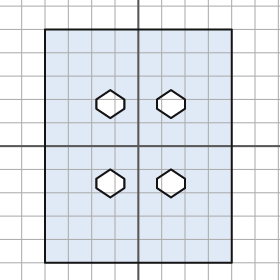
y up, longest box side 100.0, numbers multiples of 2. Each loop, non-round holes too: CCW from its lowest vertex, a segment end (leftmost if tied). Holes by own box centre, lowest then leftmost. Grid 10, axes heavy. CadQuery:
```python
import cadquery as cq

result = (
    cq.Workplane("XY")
    .moveTo(-40.0, -50.0)
    .lineTo(40.0, -50.0)
    .lineTo(40.0, 50.0)
    .lineTo(-40.0, 50.0)
    .close()
    .moveTo(-12.0, -22.0)
    .lineTo(-6.0, -18.0)
    .lineTo(-6.0, -14.0)
    .lineTo(-12.0, -10.0)
    .lineTo(-18.0, -14.0)
    .lineTo(-18.0, -18.0)
    .close()
    .moveTo(14.0, -22.0)
    .lineTo(20.0, -18.0)
    .lineTo(20.0, -14.0)
    .lineTo(14.0, -10.0)
    .lineTo(8.0, -14.0)
    .lineTo(8.0, -18.0)
    .close()
    .moveTo(-12.0, 12.0)
    .lineTo(-6.0, 16.0)
    .lineTo(-6.0, 20.0)
    .lineTo(-12.0, 24.0)
    .lineTo(-18.0, 20.0)
    .lineTo(-18.0, 16.0)
    .close()
    .moveTo(14.0, 12.0)
    .lineTo(20.0, 16.0)
    .lineTo(20.0, 20.0)
    .lineTo(14.0, 24.0)
    .lineTo(8.0, 20.0)
    .lineTo(8.0, 16.0)
    .close()
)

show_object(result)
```